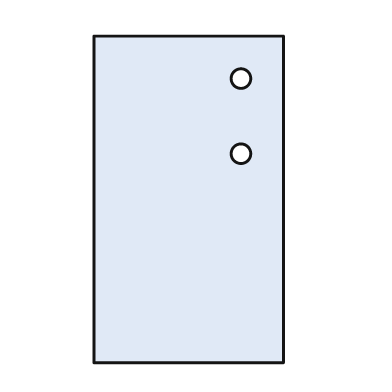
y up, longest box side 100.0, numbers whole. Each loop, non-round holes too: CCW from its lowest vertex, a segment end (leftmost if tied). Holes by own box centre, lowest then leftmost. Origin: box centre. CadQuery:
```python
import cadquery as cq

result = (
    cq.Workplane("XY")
    .moveTo(-29.0, -50.0)
    .lineTo(29.0, -50.0)
    .lineTo(29.0, 50.0)
    .lineTo(-29.0, 50.0)
    .close()
    .moveTo(16.0, 14.0)
    .circle(3.0)
    .moveTo(16.0, 37.0)
    .circle(3.0)
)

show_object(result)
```